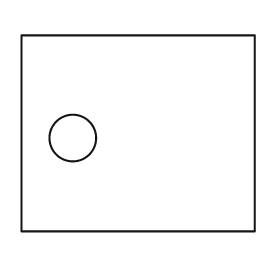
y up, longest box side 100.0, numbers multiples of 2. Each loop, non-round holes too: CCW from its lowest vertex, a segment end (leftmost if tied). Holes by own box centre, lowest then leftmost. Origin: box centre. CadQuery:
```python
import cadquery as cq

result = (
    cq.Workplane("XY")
    .moveTo(-50.0, -42.0)
    .lineTo(50.0, -42.0)
    .lineTo(50.0, 42.0)
    .lineTo(-50.0, 42.0)
    .close()
    .moveTo(-28.0, -2.0)
    .circle(10.0)
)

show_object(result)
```